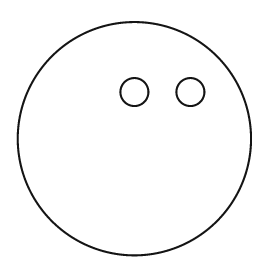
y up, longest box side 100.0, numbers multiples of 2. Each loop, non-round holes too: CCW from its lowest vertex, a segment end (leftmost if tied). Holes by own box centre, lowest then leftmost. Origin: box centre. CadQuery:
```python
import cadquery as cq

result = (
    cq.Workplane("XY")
    .moveTo(0.0, 0.0)
    .circle(50.0)
    .moveTo(0.0, 20.0)
    .circle(6.0)
    .moveTo(24.0, 20.0)
    .circle(6.0)
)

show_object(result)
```